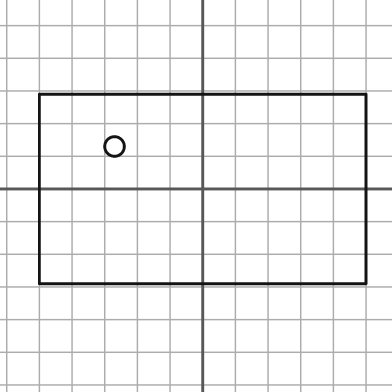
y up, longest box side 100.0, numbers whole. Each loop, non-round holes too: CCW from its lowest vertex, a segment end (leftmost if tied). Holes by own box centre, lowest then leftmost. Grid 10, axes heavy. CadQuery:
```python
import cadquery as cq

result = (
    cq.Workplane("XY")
    .moveTo(-50.0, -29.0)
    .lineTo(50.0, -29.0)
    .lineTo(50.0, 29.0)
    .lineTo(-50.0, 29.0)
    .close()
    .moveTo(-27.0, 13.0)
    .circle(3.0)
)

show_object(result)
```